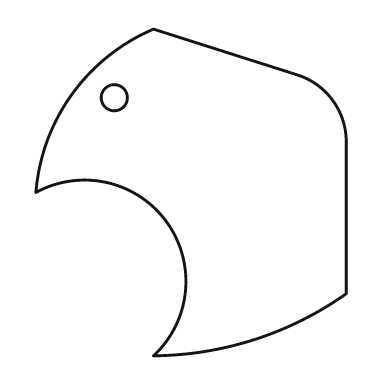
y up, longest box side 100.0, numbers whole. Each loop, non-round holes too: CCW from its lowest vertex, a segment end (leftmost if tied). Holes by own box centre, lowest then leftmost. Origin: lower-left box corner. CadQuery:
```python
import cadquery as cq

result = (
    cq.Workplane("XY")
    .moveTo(36.0, 0.0)
    .threePointArc((67.0, 5.0), (95.0, 19.0))
    .lineTo(95.0, 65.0)
    .threePointArc((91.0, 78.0), (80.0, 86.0))
    .lineTo(36.0, 100.0)
    .threePointArc((11.0, 80.0), (0.0, 50.0))
    .threePointArc((40.0, 41.0), (36.0, 0.0))
    .close()
    .moveTo(24.0, 79.0)
    .circle(4.0)
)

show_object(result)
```